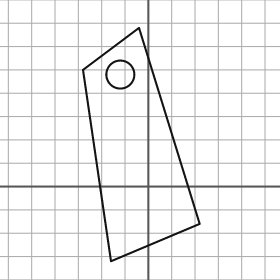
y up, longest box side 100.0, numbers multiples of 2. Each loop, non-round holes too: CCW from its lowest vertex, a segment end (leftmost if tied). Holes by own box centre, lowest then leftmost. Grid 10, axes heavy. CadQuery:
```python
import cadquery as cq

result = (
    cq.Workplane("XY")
    .moveTo(-16.0, -32.0)
    .lineTo(22.0, -16.0)
    .lineTo(-4.0, 68.0)
    .lineTo(-28.0, 50.0)
    .close()
    .moveTo(-12.0, 48.0)
    .circle(6.0)
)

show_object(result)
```